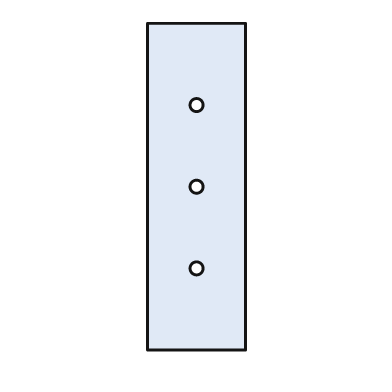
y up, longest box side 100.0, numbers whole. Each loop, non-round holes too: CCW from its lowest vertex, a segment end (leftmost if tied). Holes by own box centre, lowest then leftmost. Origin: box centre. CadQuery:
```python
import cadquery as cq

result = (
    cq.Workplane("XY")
    .moveTo(-15.0, -50.0)
    .lineTo(15.0, -50.0)
    .lineTo(15.0, 50.0)
    .lineTo(-15.0, 50.0)
    .close()
    .moveTo(0.0, -25.0)
    .circle(2.0)
    .moveTo(0.0, 0.0)
    .circle(2.0)
    .moveTo(0.0, 25.0)
    .circle(2.0)
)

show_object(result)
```